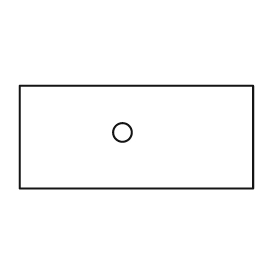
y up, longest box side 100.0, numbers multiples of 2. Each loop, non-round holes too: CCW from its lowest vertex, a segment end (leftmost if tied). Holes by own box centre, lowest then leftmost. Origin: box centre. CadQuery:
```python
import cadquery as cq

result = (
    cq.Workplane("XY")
    .moveTo(-50.0, -22.0)
    .lineTo(50.0, -22.0)
    .lineTo(50.0, 22.0)
    .lineTo(-50.0, 22.0)
    .close()
    .moveTo(-6.0, 2.0)
    .circle(4.0)
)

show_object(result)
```